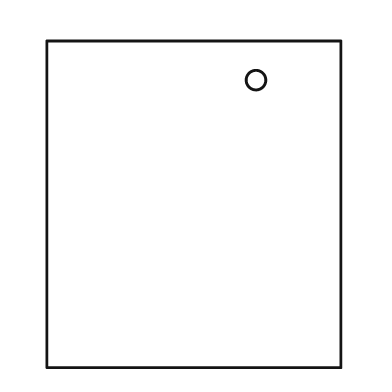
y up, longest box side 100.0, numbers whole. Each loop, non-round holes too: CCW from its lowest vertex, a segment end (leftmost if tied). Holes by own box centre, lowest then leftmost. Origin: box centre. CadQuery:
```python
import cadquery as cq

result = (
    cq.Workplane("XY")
    .moveTo(-45.0, -50.0)
    .lineTo(45.0, -50.0)
    .lineTo(45.0, 50.0)
    .lineTo(-45.0, 50.0)
    .close()
    .moveTo(19.0, 38.0)
    .circle(3.0)
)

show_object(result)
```